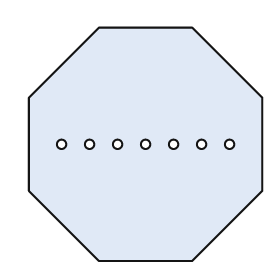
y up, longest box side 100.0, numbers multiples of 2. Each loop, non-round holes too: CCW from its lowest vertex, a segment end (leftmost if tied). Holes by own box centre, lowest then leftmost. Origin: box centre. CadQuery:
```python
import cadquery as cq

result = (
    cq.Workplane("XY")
    .moveTo(-20.0, -50.0)
    .lineTo(20.0, -50.0)
    .lineTo(50.0, -20.0)
    .lineTo(50.0, 20.0)
    .lineTo(20.0, 50.0)
    .lineTo(-20.0, 50.0)
    .lineTo(-50.0, 20.0)
    .lineTo(-50.0, -20.0)
    .close()
    .moveTo(-36.0, 0.0)
    .circle(2.0)
    .moveTo(-24.0, 0.0)
    .circle(2.0)
    .moveTo(-12.0, 0.0)
    .circle(2.0)
    .moveTo(0.0, 0.0)
    .circle(2.0)
    .moveTo(12.0, 0.0)
    .circle(2.0)
    .moveTo(24.0, 0.0)
    .circle(2.0)
    .moveTo(36.0, 0.0)
    .circle(2.0)
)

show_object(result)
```